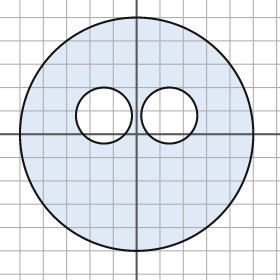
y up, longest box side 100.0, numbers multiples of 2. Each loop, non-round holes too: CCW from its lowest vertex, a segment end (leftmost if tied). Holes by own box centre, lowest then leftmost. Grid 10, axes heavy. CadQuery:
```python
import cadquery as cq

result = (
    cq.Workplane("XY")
    .moveTo(0.0, 0.0)
    .circle(50.0)
    .moveTo(-14.0, 8.0)
    .circle(12.0)
    .moveTo(14.0, 8.0)
    .circle(12.0)
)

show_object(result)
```